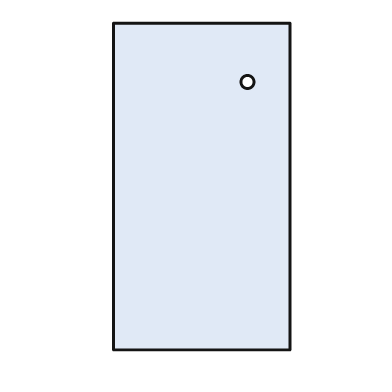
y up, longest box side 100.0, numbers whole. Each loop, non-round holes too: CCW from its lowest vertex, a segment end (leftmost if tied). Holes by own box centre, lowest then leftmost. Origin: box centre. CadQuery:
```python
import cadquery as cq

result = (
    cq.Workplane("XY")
    .moveTo(-27.0, -50.0)
    .lineTo(27.0, -50.0)
    .lineTo(27.0, 50.0)
    .lineTo(-27.0, 50.0)
    .close()
    .moveTo(14.0, 32.0)
    .circle(2.0)
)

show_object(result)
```